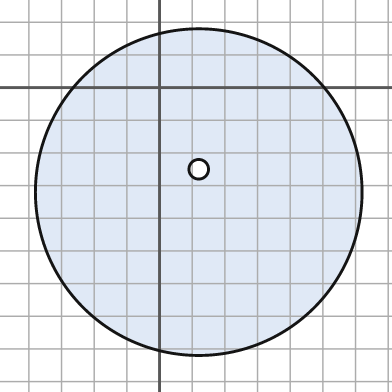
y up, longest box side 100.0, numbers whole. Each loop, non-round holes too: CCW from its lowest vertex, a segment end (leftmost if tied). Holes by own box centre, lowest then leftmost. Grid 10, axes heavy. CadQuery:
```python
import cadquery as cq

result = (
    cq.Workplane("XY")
    .moveTo(12.0, -32.0)
    .circle(50.0)
    .moveTo(12.0, -25.0)
    .circle(3.0)
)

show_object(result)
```